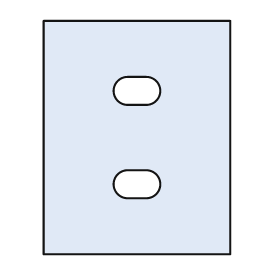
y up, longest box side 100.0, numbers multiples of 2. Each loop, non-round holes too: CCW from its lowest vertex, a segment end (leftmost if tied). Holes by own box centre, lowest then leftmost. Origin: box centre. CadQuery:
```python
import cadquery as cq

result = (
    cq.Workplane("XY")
    .moveTo(-40.0, -50.0)
    .lineTo(40.0, -50.0)
    .lineTo(40.0, 50.0)
    .lineTo(-40.0, 50.0)
    .close()
    .moveTo(-4.0, -26.0)
    .lineTo(4.0, -26.0)
    .threePointArc((10.0, -20.0), (4.0, -14.0))
    .lineTo(-4.0, -14.0)
    .threePointArc((-10.0, -20.0), (-4.0, -26.0))
    .close()
    .moveTo(-4.0, 14.0)
    .lineTo(4.0, 14.0)
    .threePointArc((10.0, 20.0), (4.0, 26.0))
    .lineTo(-4.0, 26.0)
    .threePointArc((-10.0, 20.0), (-4.0, 14.0))
    .close()
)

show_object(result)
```